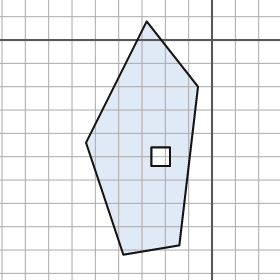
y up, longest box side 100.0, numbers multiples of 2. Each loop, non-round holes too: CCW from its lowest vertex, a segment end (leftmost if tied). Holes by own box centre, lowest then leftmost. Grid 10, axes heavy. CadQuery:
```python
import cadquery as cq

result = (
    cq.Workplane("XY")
    .moveTo(-38.0, -92.0)
    .lineTo(-14.0, -88.0)
    .lineTo(-6.0, -20.0)
    .lineTo(-28.0, 8.0)
    .lineTo(-54.0, -44.0)
    .close()
    .moveTo(-26.0, -54.0)
    .lineTo(-18.0, -54.0)
    .lineTo(-18.0, -46.0)
    .lineTo(-26.0, -46.0)
    .close()
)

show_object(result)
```